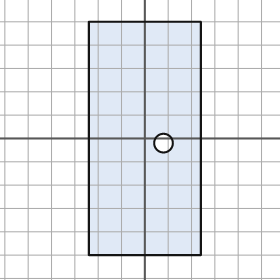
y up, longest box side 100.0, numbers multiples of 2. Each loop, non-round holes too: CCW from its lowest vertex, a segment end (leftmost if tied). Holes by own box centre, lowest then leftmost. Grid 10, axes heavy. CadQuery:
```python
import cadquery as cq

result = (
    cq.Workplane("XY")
    .moveTo(-24.0, -50.0)
    .lineTo(24.0, -50.0)
    .lineTo(24.0, 50.0)
    .lineTo(-24.0, 50.0)
    .close()
    .moveTo(8.0, -2.0)
    .circle(4.0)
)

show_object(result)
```